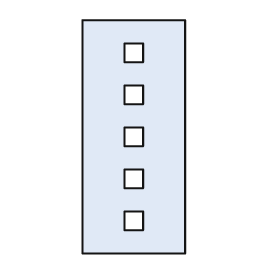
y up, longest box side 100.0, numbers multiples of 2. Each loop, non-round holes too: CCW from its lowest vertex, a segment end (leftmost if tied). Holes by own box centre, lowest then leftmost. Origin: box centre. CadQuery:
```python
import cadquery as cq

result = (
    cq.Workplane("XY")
    .moveTo(-22.0, -50.0)
    .lineTo(22.0, -50.0)
    .lineTo(22.0, 50.0)
    .lineTo(-22.0, 50.0)
    .close()
    .moveTo(-4.0, -40.0)
    .lineTo(4.0, -40.0)
    .lineTo(4.0, -32.0)
    .lineTo(-4.0, -32.0)
    .close()
    .moveTo(-4.0, -22.0)
    .lineTo(4.0, -22.0)
    .lineTo(4.0, -14.0)
    .lineTo(-4.0, -14.0)
    .close()
    .moveTo(-4.0, -4.0)
    .lineTo(4.0, -4.0)
    .lineTo(4.0, 4.0)
    .lineTo(-4.0, 4.0)
    .close()
    .moveTo(-4.0, 14.0)
    .lineTo(4.0, 14.0)
    .lineTo(4.0, 22.0)
    .lineTo(-4.0, 22.0)
    .close()
    .moveTo(-4.0, 32.0)
    .lineTo(4.0, 32.0)
    .lineTo(4.0, 40.0)
    .lineTo(-4.0, 40.0)
    .close()
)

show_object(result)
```